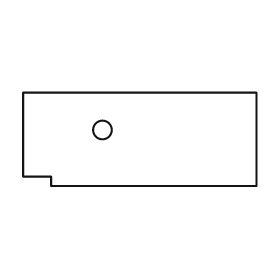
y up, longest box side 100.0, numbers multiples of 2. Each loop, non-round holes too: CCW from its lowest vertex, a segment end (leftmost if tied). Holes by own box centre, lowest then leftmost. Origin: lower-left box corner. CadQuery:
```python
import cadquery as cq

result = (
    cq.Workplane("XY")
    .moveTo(12.0, 0.0)
    .lineTo(100.0, 0.0)
    .lineTo(100.0, 40.0)
    .lineTo(0.0, 40.0)
    .lineTo(0.0, 4.0)
    .lineTo(12.0, 4.0)
    .close()
    .moveTo(34.0, 24.0)
    .circle(4.0)
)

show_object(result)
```